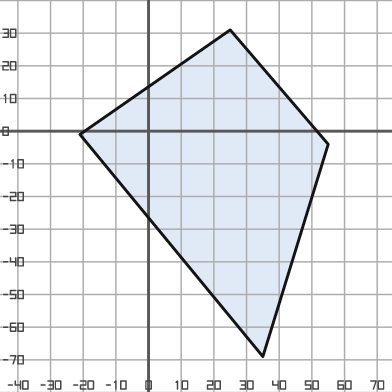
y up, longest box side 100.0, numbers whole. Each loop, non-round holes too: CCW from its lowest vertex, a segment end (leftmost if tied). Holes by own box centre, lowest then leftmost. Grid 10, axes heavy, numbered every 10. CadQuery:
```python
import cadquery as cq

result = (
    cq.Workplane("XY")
    .moveTo(35.0, -69.0)
    .lineTo(55.0, -4.0)
    .lineTo(25.0, 31.0)
    .lineTo(-21.0, -1.0)
    .close()
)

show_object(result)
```